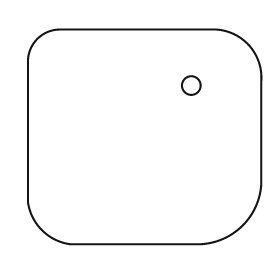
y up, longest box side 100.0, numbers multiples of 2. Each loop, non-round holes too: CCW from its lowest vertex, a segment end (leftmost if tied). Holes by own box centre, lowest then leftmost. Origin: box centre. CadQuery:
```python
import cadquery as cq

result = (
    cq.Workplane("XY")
    .moveTo(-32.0, -46.0)
    .lineTo(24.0, -46.0)
    .threePointArc((42.0, -38.0), (50.0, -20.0))
    .lineTo(50.0, 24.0)
    .threePointArc((44.0, 40.0), (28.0, 46.0))
    .lineTo(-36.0, 46.0)
    .threePointArc((-46.0, 42.0), (-50.0, 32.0))
    .lineTo(-50.0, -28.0)
    .threePointArc((-44.0, -40.0), (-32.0, -46.0))
    .close()
    .moveTo(20.0, 22.0)
    .circle(4.0)
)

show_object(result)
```